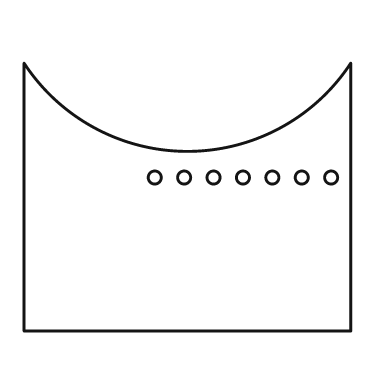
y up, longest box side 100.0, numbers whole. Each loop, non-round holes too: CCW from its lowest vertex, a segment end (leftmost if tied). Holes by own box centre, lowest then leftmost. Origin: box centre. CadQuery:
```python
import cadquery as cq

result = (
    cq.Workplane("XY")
    .moveTo(-50.0, -41.0)
    .lineTo(50.0, -41.0)
    .lineTo(50.0, 41.0)
    .threePointArc((0.0, 14.0), (-50.0, 41.0))
    .close()
    .moveTo(-10.0, 6.0)
    .circle(2.0)
    .moveTo(-1.0, 6.0)
    .circle(2.0)
    .moveTo(8.0, 6.0)
    .circle(2.0)
    .moveTo(17.0, 6.0)
    .circle(2.0)
    .moveTo(26.0, 6.0)
    .circle(2.0)
    .moveTo(35.0, 6.0)
    .circle(2.0)
    .moveTo(44.0, 6.0)
    .circle(2.0)
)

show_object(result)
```